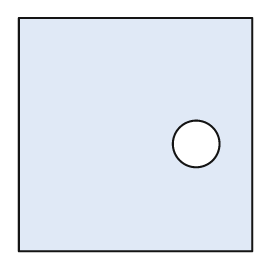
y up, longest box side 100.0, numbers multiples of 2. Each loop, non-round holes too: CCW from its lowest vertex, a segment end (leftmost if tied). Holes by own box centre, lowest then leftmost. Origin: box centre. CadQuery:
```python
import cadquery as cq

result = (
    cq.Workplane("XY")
    .moveTo(-50.0, -50.0)
    .lineTo(50.0, -50.0)
    .lineTo(50.0, 50.0)
    .lineTo(-50.0, 50.0)
    .close()
    .moveTo(26.0, -4.0)
    .circle(10.0)
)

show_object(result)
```